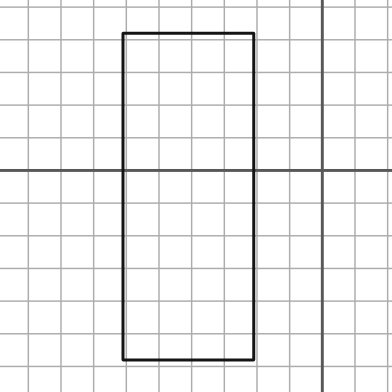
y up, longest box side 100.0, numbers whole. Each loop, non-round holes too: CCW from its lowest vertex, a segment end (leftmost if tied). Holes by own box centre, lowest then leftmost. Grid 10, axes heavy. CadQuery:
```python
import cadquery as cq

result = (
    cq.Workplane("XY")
    .moveTo(-61.0, -58.0)
    .lineTo(-21.0, -58.0)
    .lineTo(-21.0, 42.0)
    .lineTo(-61.0, 42.0)
    .close()
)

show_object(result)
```